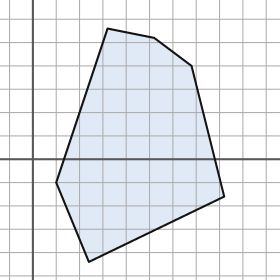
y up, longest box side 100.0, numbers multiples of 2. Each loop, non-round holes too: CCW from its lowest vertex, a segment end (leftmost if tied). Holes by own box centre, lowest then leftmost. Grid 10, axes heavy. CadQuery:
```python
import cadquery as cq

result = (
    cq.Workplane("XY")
    .moveTo(24.0, -44.0)
    .lineTo(82.0, -16.0)
    .lineTo(68.0, 40.0)
    .lineTo(52.0, 52.0)
    .lineTo(32.0, 56.0)
    .lineTo(10.0, -10.0)
    .close()
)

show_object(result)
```